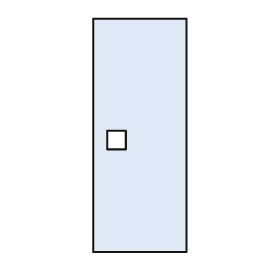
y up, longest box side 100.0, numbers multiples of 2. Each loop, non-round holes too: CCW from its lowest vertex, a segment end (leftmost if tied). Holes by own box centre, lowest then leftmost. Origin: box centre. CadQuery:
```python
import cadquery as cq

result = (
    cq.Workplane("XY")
    .moveTo(-20.0, -50.0)
    .lineTo(20.0, -50.0)
    .lineTo(20.0, 50.0)
    .lineTo(-20.0, 50.0)
    .close()
    .moveTo(-14.0, -6.0)
    .lineTo(-6.0, -6.0)
    .lineTo(-6.0, 2.0)
    .lineTo(-14.0, 2.0)
    .close()
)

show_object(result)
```